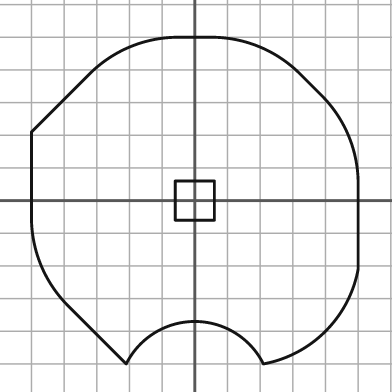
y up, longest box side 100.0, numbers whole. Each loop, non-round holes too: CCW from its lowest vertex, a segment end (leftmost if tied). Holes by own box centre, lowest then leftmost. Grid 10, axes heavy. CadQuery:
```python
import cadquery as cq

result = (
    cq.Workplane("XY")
    .moveTo(-21.0, -50.0)
    .threePointArc((0.0, -37.0), (21.0, -50.0))
    .threePointArc((40.0, -40.0), (50.0, -21.0))
    .lineTo(50.0, 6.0)
    .threePointArc((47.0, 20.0), (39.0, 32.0))
    .lineTo(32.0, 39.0)
    .threePointArc((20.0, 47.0), (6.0, 50.0))
    .lineTo(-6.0, 50.0)
    .threePointArc((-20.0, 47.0), (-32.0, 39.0))
    .lineTo(-50.0, 21.0)
    .lineTo(-50.0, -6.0)
    .threePointArc((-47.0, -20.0), (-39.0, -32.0))
    .close()
    .moveTo(-6.0, -6.0)
    .lineTo(6.0, -6.0)
    .lineTo(6.0, 6.0)
    .lineTo(-6.0, 6.0)
    .close()
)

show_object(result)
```